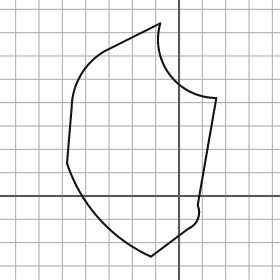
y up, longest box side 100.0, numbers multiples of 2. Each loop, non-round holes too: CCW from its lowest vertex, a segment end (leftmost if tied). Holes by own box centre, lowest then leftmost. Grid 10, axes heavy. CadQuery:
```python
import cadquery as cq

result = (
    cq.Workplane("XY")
    .moveTo(-12.0, -26.0)
    .lineTo(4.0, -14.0)
    .threePointArc((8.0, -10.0), (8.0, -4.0))
    .lineTo(16.0, 42.0)
    .threePointArc((-4.0, 52.0), (-8.0, 74.0))
    .lineTo(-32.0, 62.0)
    .threePointArc((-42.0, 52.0), (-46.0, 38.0))
    .lineTo(-48.0, 14.0)
    .threePointArc((-34.0, -10.0), (-12.0, -26.0))
    .close()
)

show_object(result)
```